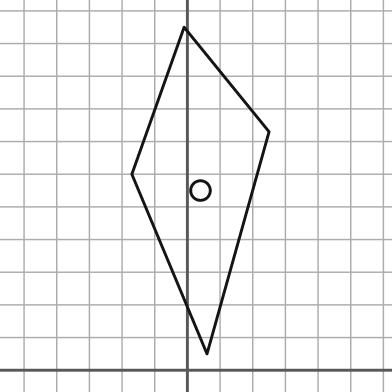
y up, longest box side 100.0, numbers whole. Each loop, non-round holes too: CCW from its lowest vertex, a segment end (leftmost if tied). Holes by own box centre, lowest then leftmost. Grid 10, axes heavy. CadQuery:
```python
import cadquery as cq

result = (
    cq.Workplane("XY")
    .moveTo(6.0, 5.0)
    .lineTo(25.0, 73.0)
    .lineTo(-1.0, 105.0)
    .lineTo(-17.0, 60.0)
    .close()
    .moveTo(4.0, 55.0)
    .circle(3.0)
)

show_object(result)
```